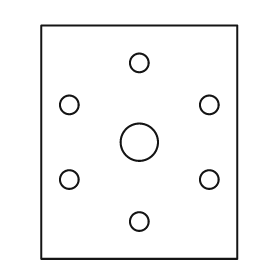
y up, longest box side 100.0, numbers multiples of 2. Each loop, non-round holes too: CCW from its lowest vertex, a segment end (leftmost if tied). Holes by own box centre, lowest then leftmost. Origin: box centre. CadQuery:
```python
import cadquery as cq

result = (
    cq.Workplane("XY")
    .moveTo(-42.0, -50.0)
    .lineTo(42.0, -50.0)
    .lineTo(42.0, 50.0)
    .lineTo(-42.0, 50.0)
    .close()
    .moveTo(0.0, -34.0)
    .circle(4.0)
    .moveTo(-30.0, -16.0)
    .circle(4.0)
    .moveTo(30.0, -16.0)
    .circle(4.0)
    .moveTo(0.0, 0.0)
    .circle(8.0)
    .moveTo(-30.0, 16.0)
    .circle(4.0)
    .moveTo(30.0, 16.0)
    .circle(4.0)
    .moveTo(0.0, 34.0)
    .circle(4.0)
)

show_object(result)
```